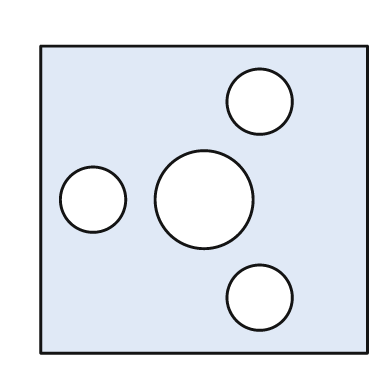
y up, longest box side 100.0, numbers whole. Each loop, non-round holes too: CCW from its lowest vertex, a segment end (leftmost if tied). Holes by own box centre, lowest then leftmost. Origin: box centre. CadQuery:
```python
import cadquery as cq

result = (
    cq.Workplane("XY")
    .moveTo(-50.0, -47.0)
    .lineTo(50.0, -47.0)
    .lineTo(50.0, 47.0)
    .lineTo(-50.0, 47.0)
    .close()
    .moveTo(17.0, -30.0)
    .circle(10.0)
    .moveTo(-34.0, 0.0)
    .circle(10.0)
    .moveTo(0.0, 0.0)
    .circle(15.0)
    .moveTo(17.0, 30.0)
    .circle(10.0)
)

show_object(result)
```